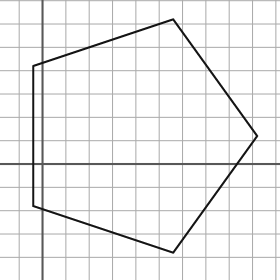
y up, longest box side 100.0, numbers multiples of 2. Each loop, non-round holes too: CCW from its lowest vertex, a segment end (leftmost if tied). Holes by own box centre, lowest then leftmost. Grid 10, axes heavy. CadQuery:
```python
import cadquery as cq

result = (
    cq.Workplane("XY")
    .moveTo(56.0, -38.0)
    .lineTo(92.0, 12.0)
    .lineTo(56.0, 62.0)
    .lineTo(-4.0, 42.0)
    .lineTo(-4.0, -18.0)
    .close()
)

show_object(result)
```